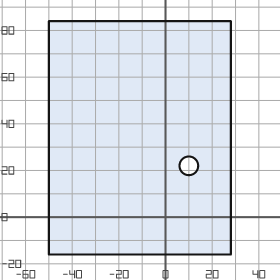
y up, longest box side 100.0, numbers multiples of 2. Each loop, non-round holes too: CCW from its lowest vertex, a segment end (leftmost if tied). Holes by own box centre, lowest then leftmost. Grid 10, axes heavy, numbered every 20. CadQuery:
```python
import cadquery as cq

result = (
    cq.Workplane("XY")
    .moveTo(-50.0, -16.0)
    .lineTo(28.0, -16.0)
    .lineTo(28.0, 84.0)
    .lineTo(-50.0, 84.0)
    .close()
    .moveTo(10.0, 22.0)
    .circle(4.0)
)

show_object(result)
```